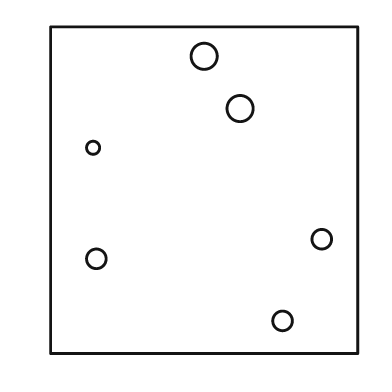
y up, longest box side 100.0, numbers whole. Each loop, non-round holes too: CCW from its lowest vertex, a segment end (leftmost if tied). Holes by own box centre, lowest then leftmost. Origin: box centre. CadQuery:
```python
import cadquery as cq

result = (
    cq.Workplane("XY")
    .moveTo(-47.0, -50.0)
    .lineTo(47.0, -50.0)
    .lineTo(47.0, 50.0)
    .lineTo(-47.0, 50.0)
    .close()
    .moveTo(24.0, -40.0)
    .circle(3.0)
    .moveTo(-33.0, -21.0)
    .circle(3.0)
    .moveTo(36.0, -15.0)
    .circle(3.0)
    .moveTo(-34.0, 13.0)
    .circle(2.0)
    .moveTo(11.0, 25.0)
    .circle(4.0)
    .moveTo(0.0, 41.0)
    .circle(4.0)
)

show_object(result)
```